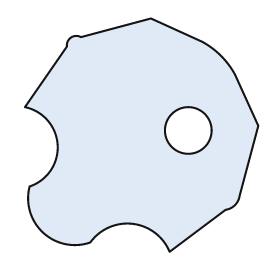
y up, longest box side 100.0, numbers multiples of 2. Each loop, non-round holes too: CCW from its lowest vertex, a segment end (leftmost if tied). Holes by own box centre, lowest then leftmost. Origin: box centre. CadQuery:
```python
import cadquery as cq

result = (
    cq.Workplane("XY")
    .moveTo(12.0, -50.0)
    .lineTo(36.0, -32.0)
    .threePointArc((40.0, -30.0), (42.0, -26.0))
    .lineTo(50.0, 4.0)
    .lineTo(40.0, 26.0)
    .threePointArc((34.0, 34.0), (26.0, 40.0))
    .lineTo(4.0, 50.0)
    .lineTo(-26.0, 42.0)
    .threePointArc((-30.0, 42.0), (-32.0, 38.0))
    .lineTo(-50.0, 12.0)
    .threePointArc((-36.0, -4.0), (-48.0, -22.0))
    .threePointArc((-42.0, -42.0), (-22.0, -46.0))
    .threePointArc((-4.0, -38.0), (12.0, -50.0))
    .close()
    .moveTo(20.0, 2.0)
    .circle(10.0)
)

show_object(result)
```